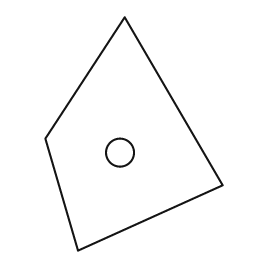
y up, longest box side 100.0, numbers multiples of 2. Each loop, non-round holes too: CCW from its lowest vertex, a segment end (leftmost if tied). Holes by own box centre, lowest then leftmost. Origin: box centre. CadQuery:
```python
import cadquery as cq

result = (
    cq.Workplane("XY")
    .moveTo(-24.0, -50.0)
    .lineTo(38.0, -22.0)
    .lineTo(-4.0, 50.0)
    .lineTo(-38.0, -2.0)
    .close()
    .moveTo(-6.0, -8.0)
    .circle(6.0)
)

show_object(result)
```